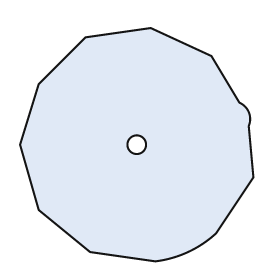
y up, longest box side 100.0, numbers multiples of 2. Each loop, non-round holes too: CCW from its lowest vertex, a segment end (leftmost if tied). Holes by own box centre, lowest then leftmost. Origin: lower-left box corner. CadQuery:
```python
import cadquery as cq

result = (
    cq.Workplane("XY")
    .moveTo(58.0, 0.0)
    .threePointArc((72.0, 4.0), (84.0, 12.0))
    .lineTo(100.0, 36.0)
    .lineTo(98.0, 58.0)
    .threePointArc((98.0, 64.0), (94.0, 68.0))
    .lineTo(82.0, 88.0)
    .lineTo(56.0, 100.0)
    .lineTo(28.0, 96.0)
    .lineTo(8.0, 76.0)
    .lineTo(0.0, 50.0)
    .lineTo(8.0, 22.0)
    .lineTo(30.0, 4.0)
    .close()
    .moveTo(50.0, 50.0)
    .circle(4.0)
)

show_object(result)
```